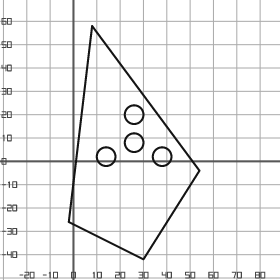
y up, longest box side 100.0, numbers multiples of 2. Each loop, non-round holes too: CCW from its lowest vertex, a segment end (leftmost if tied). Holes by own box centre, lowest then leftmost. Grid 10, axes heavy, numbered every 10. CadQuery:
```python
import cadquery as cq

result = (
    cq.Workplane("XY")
    .moveTo(30.0, -42.0)
    .lineTo(54.0, -4.0)
    .lineTo(8.0, 58.0)
    .lineTo(-2.0, -26.0)
    .close()
    .moveTo(14.0, 2.0)
    .circle(4.0)
    .moveTo(38.0, 2.0)
    .circle(4.0)
    .moveTo(26.0, 8.0)
    .circle(4.0)
    .moveTo(26.0, 20.0)
    .circle(4.0)
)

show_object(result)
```